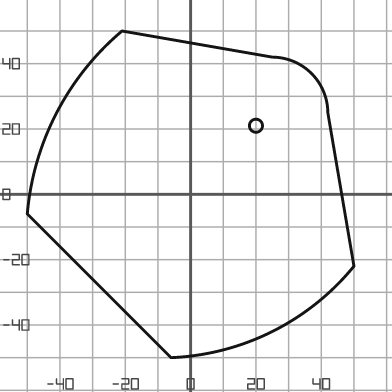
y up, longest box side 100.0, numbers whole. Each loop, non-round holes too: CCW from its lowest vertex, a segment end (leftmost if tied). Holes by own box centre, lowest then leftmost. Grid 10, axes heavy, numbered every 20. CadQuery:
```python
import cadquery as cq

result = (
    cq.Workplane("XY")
    .moveTo(-6.0, -50.0)
    .threePointArc((25.0, -42.0), (50.0, -22.0))
    .lineTo(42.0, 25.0)
    .threePointArc((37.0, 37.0), (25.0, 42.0))
    .lineTo(-21.0, 50.0)
    .threePointArc((-41.0, 25.0), (-50.0, -6.0))
    .close()
    .moveTo(20.0, 21.0)
    .circle(2.0)
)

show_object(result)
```